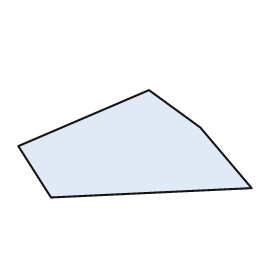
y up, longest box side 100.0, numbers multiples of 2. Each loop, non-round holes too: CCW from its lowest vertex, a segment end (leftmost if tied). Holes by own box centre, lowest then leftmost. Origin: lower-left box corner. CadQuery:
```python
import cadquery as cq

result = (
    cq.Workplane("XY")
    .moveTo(14.0, 0.0)
    .lineTo(100.0, 4.0)
    .lineTo(78.0, 30.0)
    .lineTo(56.0, 46.0)
    .lineTo(0.0, 22.0)
    .close()
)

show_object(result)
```